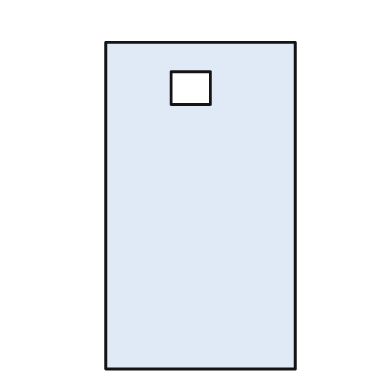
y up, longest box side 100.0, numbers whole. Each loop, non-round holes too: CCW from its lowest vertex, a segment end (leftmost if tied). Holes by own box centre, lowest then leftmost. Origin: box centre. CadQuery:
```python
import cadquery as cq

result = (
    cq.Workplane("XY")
    .moveTo(-29.0, -50.0)
    .lineTo(29.0, -50.0)
    .lineTo(29.0, 50.0)
    .lineTo(-29.0, 50.0)
    .close()
    .moveTo(-9.0, 31.0)
    .lineTo(3.0, 31.0)
    .lineTo(3.0, 41.0)
    .lineTo(-9.0, 41.0)
    .close()
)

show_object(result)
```